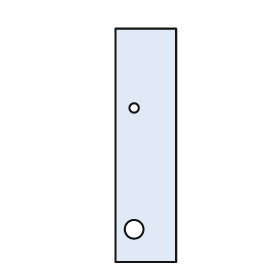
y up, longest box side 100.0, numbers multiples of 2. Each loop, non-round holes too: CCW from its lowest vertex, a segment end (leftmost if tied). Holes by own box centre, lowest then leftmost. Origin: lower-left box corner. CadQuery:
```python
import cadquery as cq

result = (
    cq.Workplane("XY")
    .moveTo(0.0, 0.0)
    .lineTo(26.0, 0.0)
    .lineTo(26.0, 100.0)
    .lineTo(0.0, 100.0)
    .close()
    .moveTo(8.0, 14.0)
    .circle(4.0)
    .moveTo(8.0, 66.0)
    .circle(2.0)
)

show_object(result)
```